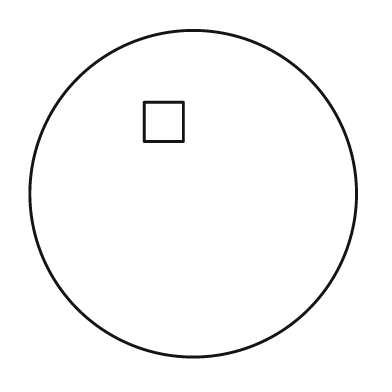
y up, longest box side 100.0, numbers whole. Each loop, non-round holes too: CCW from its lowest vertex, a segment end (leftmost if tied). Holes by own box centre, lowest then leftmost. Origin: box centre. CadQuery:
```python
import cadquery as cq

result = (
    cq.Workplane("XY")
    .moveTo(0.0, 0.0)
    .circle(50.0)
    .moveTo(-15.0, 16.0)
    .lineTo(-3.0, 16.0)
    .lineTo(-3.0, 28.0)
    .lineTo(-15.0, 28.0)
    .close()
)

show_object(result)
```